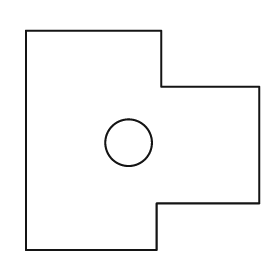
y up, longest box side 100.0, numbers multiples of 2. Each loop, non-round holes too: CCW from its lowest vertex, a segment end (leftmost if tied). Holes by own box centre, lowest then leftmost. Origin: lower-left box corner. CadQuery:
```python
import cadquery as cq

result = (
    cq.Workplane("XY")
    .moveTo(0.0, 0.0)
    .lineTo(56.0, 0.0)
    .lineTo(56.0, 20.0)
    .lineTo(100.0, 20.0)
    .lineTo(100.0, 70.0)
    .lineTo(58.0, 70.0)
    .lineTo(58.0, 94.0)
    .lineTo(0.0, 94.0)
    .close()
    .moveTo(44.0, 46.0)
    .circle(10.0)
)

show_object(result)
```